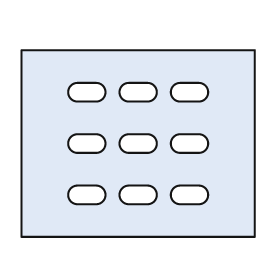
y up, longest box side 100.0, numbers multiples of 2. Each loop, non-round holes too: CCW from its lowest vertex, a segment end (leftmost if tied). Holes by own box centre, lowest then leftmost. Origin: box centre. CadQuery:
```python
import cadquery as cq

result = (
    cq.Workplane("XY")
    .moveTo(-50.0, -40.0)
    .lineTo(50.0, -40.0)
    .lineTo(50.0, 40.0)
    .lineTo(-50.0, 40.0)
    .close()
    .moveTo(-26.0, -26.0)
    .lineTo(-18.0, -26.0)
    .threePointArc((-14.0, -22.0), (-18.0, -18.0))
    .lineTo(-26.0, -18.0)
    .threePointArc((-30.0, -22.0), (-26.0, -26.0))
    .close()
    .moveTo(-4.0, -26.0)
    .lineTo(4.0, -26.0)
    .threePointArc((8.0, -22.0), (4.0, -18.0))
    .lineTo(-4.0, -18.0)
    .threePointArc((-8.0, -22.0), (-4.0, -26.0))
    .close()
    .moveTo(18.0, -26.0)
    .lineTo(26.0, -26.0)
    .threePointArc((30.0, -22.0), (26.0, -18.0))
    .lineTo(18.0, -18.0)
    .threePointArc((14.0, -22.0), (18.0, -26.0))
    .close()
    .moveTo(-26.0, -4.0)
    .lineTo(-18.0, -4.0)
    .threePointArc((-14.0, 0.0), (-18.0, 4.0))
    .lineTo(-26.0, 4.0)
    .threePointArc((-30.0, 0.0), (-26.0, -4.0))
    .close()
    .moveTo(-4.0, -4.0)
    .lineTo(4.0, -4.0)
    .threePointArc((8.0, 0.0), (4.0, 4.0))
    .lineTo(-4.0, 4.0)
    .threePointArc((-8.0, 0.0), (-4.0, -4.0))
    .close()
    .moveTo(18.0, -4.0)
    .lineTo(26.0, -4.0)
    .threePointArc((30.0, 0.0), (26.0, 4.0))
    .lineTo(18.0, 4.0)
    .threePointArc((14.0, 0.0), (18.0, -4.0))
    .close()
    .moveTo(-26.0, 18.0)
    .lineTo(-18.0, 18.0)
    .threePointArc((-14.0, 22.0), (-18.0, 26.0))
    .lineTo(-26.0, 26.0)
    .threePointArc((-30.0, 22.0), (-26.0, 18.0))
    .close()
    .moveTo(-4.0, 18.0)
    .lineTo(4.0, 18.0)
    .threePointArc((8.0, 22.0), (4.0, 26.0))
    .lineTo(-4.0, 26.0)
    .threePointArc((-8.0, 22.0), (-4.0, 18.0))
    .close()
    .moveTo(18.0, 18.0)
    .lineTo(26.0, 18.0)
    .threePointArc((30.0, 22.0), (26.0, 26.0))
    .lineTo(18.0, 26.0)
    .threePointArc((14.0, 22.0), (18.0, 18.0))
    .close()
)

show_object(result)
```